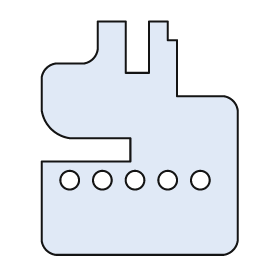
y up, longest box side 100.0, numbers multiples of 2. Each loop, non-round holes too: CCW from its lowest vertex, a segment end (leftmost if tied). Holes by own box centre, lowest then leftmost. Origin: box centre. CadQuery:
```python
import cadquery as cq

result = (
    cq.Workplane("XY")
    .moveTo(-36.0, -50.0)
    .lineTo(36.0, -50.0)
    .threePointArc((40.0, -48.0), (42.0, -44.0))
    .lineTo(42.0, 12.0)
    .threePointArc((40.0, 16.0), (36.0, 18.0))
    .lineTo(16.0, 18.0)
    .lineTo(16.0, 42.0)
    .lineTo(12.0, 42.0)
    .lineTo(12.0, 50.0)
    .lineTo(4.0, 50.0)
    .lineTo(4.0, 28.0)
    .lineTo(-6.0, 28.0)
    .lineTo(-6.0, 50.0)
    .lineTo(-18.0, 50.0)
    .lineTo(-18.0, 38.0)
    .threePointArc((-20.0, 34.0), (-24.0, 32.0))
    .lineTo(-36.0, 32.0)
    .threePointArc((-40.0, 30.0), (-42.0, 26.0))
    .lineTo(-42.0, 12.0)
    .threePointArc((-38.0, 4.0), (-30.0, 0.0))
    .lineTo(-4.0, 0.0)
    .lineTo(-4.0, -10.0)
    .lineTo(-42.0, -10.0)
    .lineTo(-42.0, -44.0)
    .threePointArc((-40.0, -48.0), (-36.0, -50.0))
    .close()
    .moveTo(-30.0, -18.0)
    .circle(4.0)
    .moveTo(-16.0, -18.0)
    .circle(4.0)
    .moveTo(-2.0, -18.0)
    .circle(4.0)
    .moveTo(12.0, -18.0)
    .circle(4.0)
    .moveTo(26.0, -18.0)
    .circle(4.0)
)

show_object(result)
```